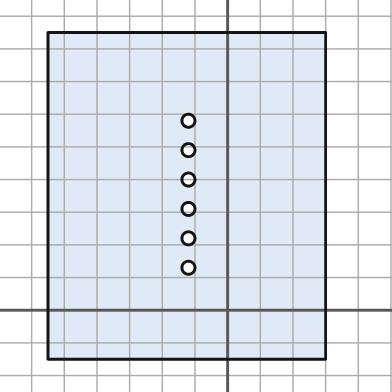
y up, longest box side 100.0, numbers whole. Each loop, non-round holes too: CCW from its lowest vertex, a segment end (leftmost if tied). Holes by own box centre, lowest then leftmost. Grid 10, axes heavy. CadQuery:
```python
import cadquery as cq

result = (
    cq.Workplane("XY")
    .moveTo(-55.0, -15.0)
    .lineTo(30.0, -15.0)
    .lineTo(30.0, 85.0)
    .lineTo(-55.0, 85.0)
    .close()
    .moveTo(-12.0, 13.0)
    .circle(2.0)
    .moveTo(-12.0, 22.0)
    .circle(2.0)
    .moveTo(-12.0, 31.0)
    .circle(2.0)
    .moveTo(-12.0, 40.0)
    .circle(2.0)
    .moveTo(-12.0, 49.0)
    .circle(2.0)
    .moveTo(-12.0, 58.0)
    .circle(2.0)
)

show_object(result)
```